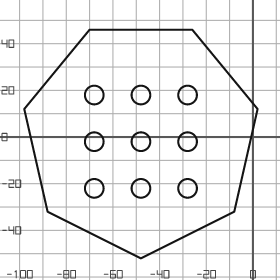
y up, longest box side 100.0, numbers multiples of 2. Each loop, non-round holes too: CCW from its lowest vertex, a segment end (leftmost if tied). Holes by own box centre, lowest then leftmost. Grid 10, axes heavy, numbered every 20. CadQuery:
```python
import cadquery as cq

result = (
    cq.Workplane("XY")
    .moveTo(-48.0, -52.0)
    .lineTo(-8.0, -32.0)
    .lineTo(2.0, 12.0)
    .lineTo(-26.0, 46.0)
    .lineTo(-70.0, 46.0)
    .lineTo(-98.0, 12.0)
    .lineTo(-88.0, -32.0)
    .close()
    .moveTo(-68.0, -22.0)
    .circle(4.0)
    .moveTo(-48.0, -22.0)
    .circle(4.0)
    .moveTo(-28.0, -22.0)
    .circle(4.0)
    .moveTo(-68.0, -2.0)
    .circle(4.0)
    .moveTo(-48.0, -2.0)
    .circle(4.0)
    .moveTo(-28.0, -2.0)
    .circle(4.0)
    .moveTo(-68.0, 18.0)
    .circle(4.0)
    .moveTo(-48.0, 18.0)
    .circle(4.0)
    .moveTo(-28.0, 18.0)
    .circle(4.0)
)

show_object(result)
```